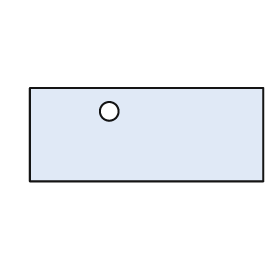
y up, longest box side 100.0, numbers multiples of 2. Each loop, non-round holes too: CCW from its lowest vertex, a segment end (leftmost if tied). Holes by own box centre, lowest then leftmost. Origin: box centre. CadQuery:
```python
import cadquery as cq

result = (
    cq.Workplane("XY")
    .moveTo(-50.0, -20.0)
    .lineTo(50.0, -20.0)
    .lineTo(50.0, 20.0)
    .lineTo(-50.0, 20.0)
    .close()
    .moveTo(-16.0, 10.0)
    .circle(4.0)
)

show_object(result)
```